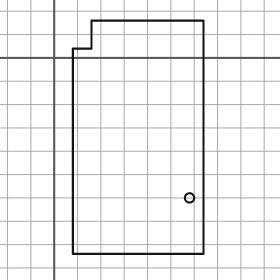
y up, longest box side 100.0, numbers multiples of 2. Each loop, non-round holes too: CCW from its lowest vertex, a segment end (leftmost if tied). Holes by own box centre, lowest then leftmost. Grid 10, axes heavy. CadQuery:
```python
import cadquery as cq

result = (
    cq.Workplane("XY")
    .moveTo(8.0, -84.0)
    .lineTo(64.0, -84.0)
    .lineTo(64.0, 16.0)
    .lineTo(16.0, 16.0)
    .lineTo(16.0, 4.0)
    .lineTo(8.0, 4.0)
    .close()
    .moveTo(58.0, -60.0)
    .circle(2.0)
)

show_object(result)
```